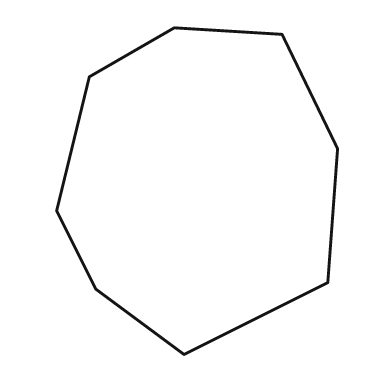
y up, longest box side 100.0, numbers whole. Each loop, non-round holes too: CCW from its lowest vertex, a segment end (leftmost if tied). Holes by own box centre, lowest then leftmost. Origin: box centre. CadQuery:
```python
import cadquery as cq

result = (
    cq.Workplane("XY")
    .moveTo(-4.0, -50.0)
    .lineTo(40.0, -28.0)
    .lineTo(43.0, 13.0)
    .lineTo(26.0, 48.0)
    .lineTo(-7.0, 50.0)
    .lineTo(-33.0, 35.0)
    .lineTo(-43.0, -6.0)
    .lineTo(-31.0, -30.0)
    .close()
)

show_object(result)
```